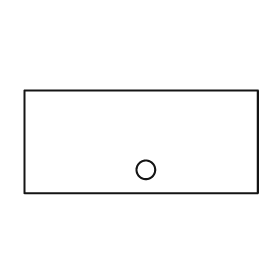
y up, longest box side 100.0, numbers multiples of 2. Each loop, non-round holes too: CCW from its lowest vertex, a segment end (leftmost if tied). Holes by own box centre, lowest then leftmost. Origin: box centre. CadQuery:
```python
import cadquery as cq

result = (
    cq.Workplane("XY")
    .moveTo(-50.0, -22.0)
    .lineTo(50.0, -22.0)
    .lineTo(50.0, 22.0)
    .lineTo(-50.0, 22.0)
    .close()
    .moveTo(2.0, -12.0)
    .circle(4.0)
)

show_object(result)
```